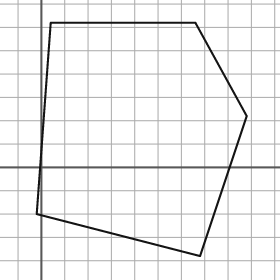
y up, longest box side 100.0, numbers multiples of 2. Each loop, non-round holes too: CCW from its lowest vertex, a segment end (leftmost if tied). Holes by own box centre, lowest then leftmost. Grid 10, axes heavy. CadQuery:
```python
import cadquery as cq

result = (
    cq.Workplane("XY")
    .moveTo(68.0, -38.0)
    .lineTo(88.0, 22.0)
    .lineTo(66.0, 62.0)
    .lineTo(4.0, 62.0)
    .lineTo(-2.0, -20.0)
    .close()
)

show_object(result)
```